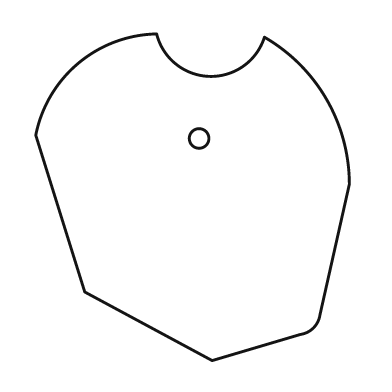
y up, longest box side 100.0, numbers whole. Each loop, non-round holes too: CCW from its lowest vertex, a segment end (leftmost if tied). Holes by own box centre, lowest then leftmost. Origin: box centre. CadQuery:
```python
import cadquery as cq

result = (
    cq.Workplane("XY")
    .moveTo(6.0, -50.0)
    .lineTo(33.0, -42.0)
    .threePointArc((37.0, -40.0), (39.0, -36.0))
    .lineTo(48.0, 4.0)
    .threePointArc((41.0, 30.0), (22.0, 49.0))
    .threePointArc((5.0, 37.0), (-11.0, 50.0))
    .threePointArc((-35.0, 41.0), (-48.0, 19.0))
    .lineTo(-33.0, -29.0)
    .close()
    .moveTo(2.0, 18.0)
    .circle(3.0)
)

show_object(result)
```